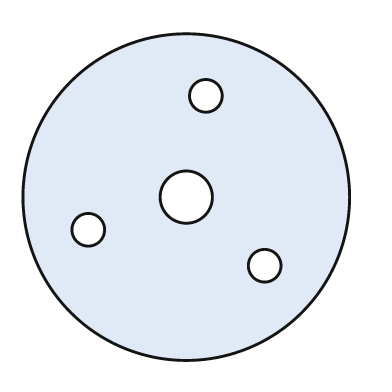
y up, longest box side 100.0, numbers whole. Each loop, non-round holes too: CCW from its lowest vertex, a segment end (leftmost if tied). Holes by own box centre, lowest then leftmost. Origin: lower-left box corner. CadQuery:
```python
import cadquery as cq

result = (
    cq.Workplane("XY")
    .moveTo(50.0, 50.0)
    .circle(50.0)
    .moveTo(74.0, 29.0)
    .circle(5.0)
    .moveTo(20.0, 40.0)
    .circle(5.0)
    .moveTo(50.0, 50.0)
    .circle(8.0)
    .moveTo(56.0, 81.0)
    .circle(5.0)
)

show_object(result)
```